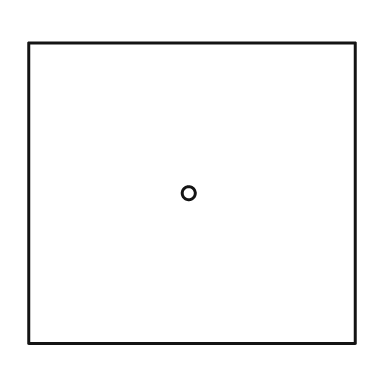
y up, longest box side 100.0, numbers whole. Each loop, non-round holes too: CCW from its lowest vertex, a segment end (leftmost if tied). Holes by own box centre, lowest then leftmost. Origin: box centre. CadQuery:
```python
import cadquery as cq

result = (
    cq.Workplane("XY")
    .moveTo(-50.0, -46.0)
    .lineTo(50.0, -46.0)
    .lineTo(50.0, 46.0)
    .lineTo(-50.0, 46.0)
    .close()
    .moveTo(-1.0, 0.0)
    .circle(2.0)
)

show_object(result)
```